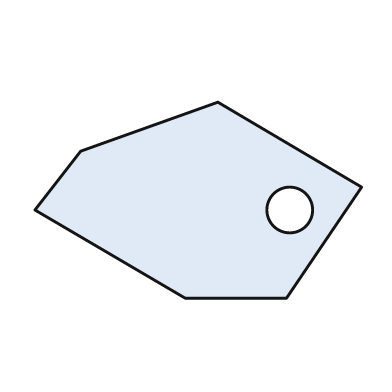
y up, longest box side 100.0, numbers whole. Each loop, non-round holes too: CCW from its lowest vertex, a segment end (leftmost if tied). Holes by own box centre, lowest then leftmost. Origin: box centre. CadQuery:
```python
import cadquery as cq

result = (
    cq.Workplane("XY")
    .moveTo(-4.0, -30.0)
    .lineTo(27.0, -30.0)
    .lineTo(50.0, 4.0)
    .lineTo(6.0, 30.0)
    .lineTo(-36.0, 15.0)
    .lineTo(-50.0, -3.0)
    .close()
    .moveTo(28.0, -3.0)
    .circle(7.0)
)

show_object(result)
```